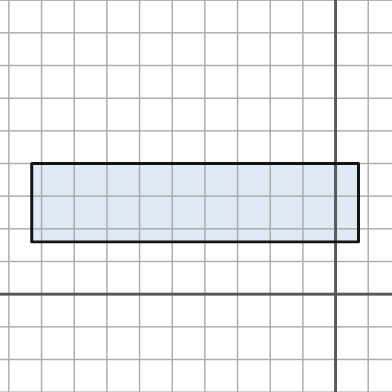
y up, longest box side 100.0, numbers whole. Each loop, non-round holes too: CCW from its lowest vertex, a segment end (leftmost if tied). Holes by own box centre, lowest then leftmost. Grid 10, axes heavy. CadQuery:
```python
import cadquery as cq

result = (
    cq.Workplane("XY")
    .moveTo(-93.0, 16.0)
    .lineTo(7.0, 16.0)
    .lineTo(7.0, 40.0)
    .lineTo(-93.0, 40.0)
    .close()
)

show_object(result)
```